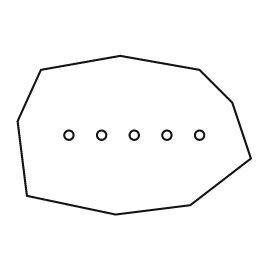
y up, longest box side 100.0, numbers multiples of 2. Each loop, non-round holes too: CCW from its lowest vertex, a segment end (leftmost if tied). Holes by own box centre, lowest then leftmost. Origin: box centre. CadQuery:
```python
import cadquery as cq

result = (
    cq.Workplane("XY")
    .moveTo(-8.0, -34.0)
    .lineTo(24.0, -30.0)
    .lineTo(50.0, -10.0)
    .lineTo(42.0, 14.0)
    .lineTo(28.0, 28.0)
    .lineTo(-6.0, 34.0)
    .lineTo(-40.0, 28.0)
    .lineTo(-50.0, 6.0)
    .lineTo(-46.0, -26.0)
    .close()
    .moveTo(-28.0, 0.0)
    .circle(2.0)
    .moveTo(-14.0, 0.0)
    .circle(2.0)
    .moveTo(0.0, 0.0)
    .circle(2.0)
    .moveTo(14.0, 0.0)
    .circle(2.0)
    .moveTo(28.0, 0.0)
    .circle(2.0)
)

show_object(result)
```